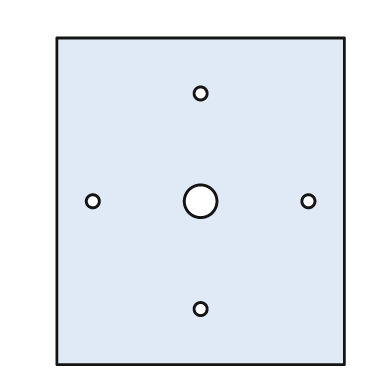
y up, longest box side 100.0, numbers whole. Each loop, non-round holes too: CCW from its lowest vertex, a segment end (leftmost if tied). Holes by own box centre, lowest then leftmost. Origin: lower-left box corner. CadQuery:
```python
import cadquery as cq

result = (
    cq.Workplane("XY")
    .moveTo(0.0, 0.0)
    .lineTo(88.0, 0.0)
    .lineTo(88.0, 100.0)
    .lineTo(0.0, 100.0)
    .close()
    .moveTo(44.0, 17.0)
    .circle(2.0)
    .moveTo(11.0, 50.0)
    .circle(2.0)
    .moveTo(44.0, 50.0)
    .circle(5.0)
    .moveTo(77.0, 50.0)
    .circle(2.0)
    .moveTo(44.0, 83.0)
    .circle(2.0)
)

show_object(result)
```